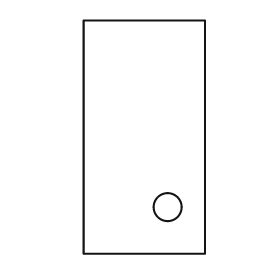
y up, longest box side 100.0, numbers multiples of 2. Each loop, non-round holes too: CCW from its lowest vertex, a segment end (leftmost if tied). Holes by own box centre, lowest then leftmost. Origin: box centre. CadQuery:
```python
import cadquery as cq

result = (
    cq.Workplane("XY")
    .moveTo(-26.0, -50.0)
    .lineTo(26.0, -50.0)
    .lineTo(26.0, 50.0)
    .lineTo(-26.0, 50.0)
    .close()
    .moveTo(10.0, -30.0)
    .circle(6.0)
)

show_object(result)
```